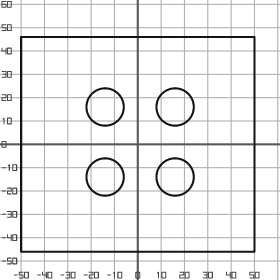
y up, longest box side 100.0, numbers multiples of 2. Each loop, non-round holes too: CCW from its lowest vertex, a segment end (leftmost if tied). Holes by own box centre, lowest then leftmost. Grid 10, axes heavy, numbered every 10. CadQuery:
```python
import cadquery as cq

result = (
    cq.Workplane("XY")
    .moveTo(-50.0, -46.0)
    .lineTo(50.0, -46.0)
    .lineTo(50.0, 46.0)
    .lineTo(-50.0, 46.0)
    .close()
    .moveTo(-14.0, -14.0)
    .circle(8.0)
    .moveTo(16.0, -14.0)
    .circle(8.0)
    .moveTo(-14.0, 16.0)
    .circle(8.0)
    .moveTo(16.0, 16.0)
    .circle(8.0)
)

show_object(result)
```